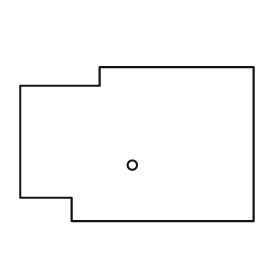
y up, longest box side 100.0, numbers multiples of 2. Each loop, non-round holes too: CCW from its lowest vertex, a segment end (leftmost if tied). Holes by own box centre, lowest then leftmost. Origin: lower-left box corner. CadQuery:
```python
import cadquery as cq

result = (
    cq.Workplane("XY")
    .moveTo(22.0, 0.0)
    .lineTo(100.0, 0.0)
    .lineTo(100.0, 66.0)
    .lineTo(34.0, 66.0)
    .lineTo(34.0, 58.0)
    .lineTo(0.0, 58.0)
    .lineTo(0.0, 10.0)
    .lineTo(22.0, 10.0)
    .close()
    .moveTo(48.0, 24.0)
    .circle(2.0)
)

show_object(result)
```